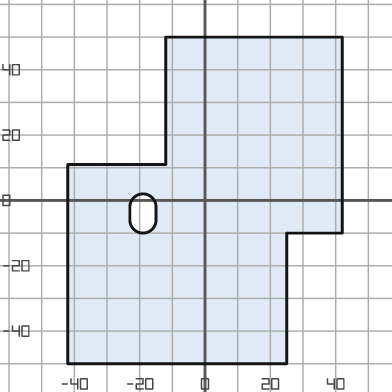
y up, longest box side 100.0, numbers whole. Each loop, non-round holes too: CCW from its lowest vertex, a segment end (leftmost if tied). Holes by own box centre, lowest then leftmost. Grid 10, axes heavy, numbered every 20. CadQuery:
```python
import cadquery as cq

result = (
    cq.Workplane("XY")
    .moveTo(-42.0, -50.0)
    .lineTo(25.0, -50.0)
    .lineTo(25.0, -10.0)
    .lineTo(42.0, -10.0)
    .lineTo(42.0, 50.0)
    .lineTo(-12.0, 50.0)
    .lineTo(-12.0, 11.0)
    .lineTo(-42.0, 11.0)
    .close()
    .moveTo(-23.0, -6.0)
    .threePointArc((-19.0, -10.0), (-15.0, -6.0))
    .lineTo(-15.0, -2.0)
    .threePointArc((-19.0, 2.0), (-23.0, -2.0))
    .close()
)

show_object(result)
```